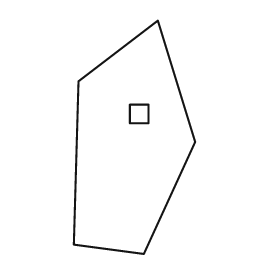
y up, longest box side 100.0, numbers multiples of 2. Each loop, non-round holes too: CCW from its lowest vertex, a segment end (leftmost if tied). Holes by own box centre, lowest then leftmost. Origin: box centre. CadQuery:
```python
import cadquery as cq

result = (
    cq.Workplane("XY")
    .moveTo(4.0, -50.0)
    .lineTo(26.0, -2.0)
    .lineTo(10.0, 50.0)
    .lineTo(-24.0, 24.0)
    .lineTo(-26.0, -46.0)
    .close()
    .moveTo(-2.0, 6.0)
    .lineTo(6.0, 6.0)
    .lineTo(6.0, 14.0)
    .lineTo(-2.0, 14.0)
    .close()
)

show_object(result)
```